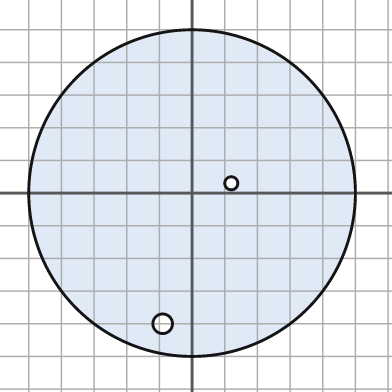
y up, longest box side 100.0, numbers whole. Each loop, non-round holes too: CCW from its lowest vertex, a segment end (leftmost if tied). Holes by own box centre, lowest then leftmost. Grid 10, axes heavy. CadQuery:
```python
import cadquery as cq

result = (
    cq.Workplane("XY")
    .moveTo(0.0, 0.0)
    .circle(50.0)
    .moveTo(-9.0, -40.0)
    .circle(3.0)
    .moveTo(12.0, 3.0)
    .circle(2.0)
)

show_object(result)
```